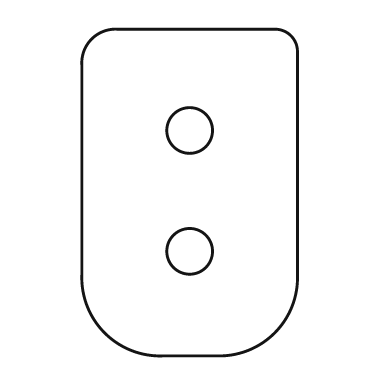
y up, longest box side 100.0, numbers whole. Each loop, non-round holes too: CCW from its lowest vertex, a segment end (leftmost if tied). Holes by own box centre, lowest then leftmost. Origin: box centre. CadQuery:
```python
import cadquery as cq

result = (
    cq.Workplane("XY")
    .moveTo(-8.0, -50.0)
    .lineTo(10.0, -50.0)
    .threePointArc((26.0, -43.0), (33.0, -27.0))
    .lineTo(33.0, 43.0)
    .threePointArc((31.0, 48.0), (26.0, 50.0))
    .lineTo(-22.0, 50.0)
    .threePointArc((-30.0, 47.0), (-33.0, 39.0))
    .lineTo(-33.0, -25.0)
    .threePointArc((-26.0, -43.0), (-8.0, -50.0))
    .close()
    .moveTo(0.0, -18.0)
    .circle(7.0)
    .moveTo(0.0, 19.0)
    .circle(7.0)
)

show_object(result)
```